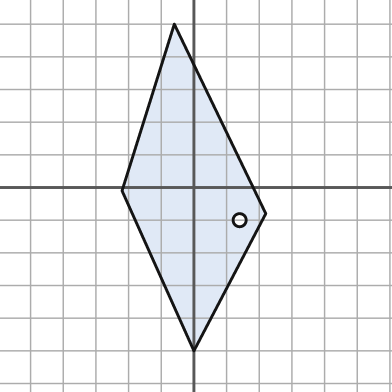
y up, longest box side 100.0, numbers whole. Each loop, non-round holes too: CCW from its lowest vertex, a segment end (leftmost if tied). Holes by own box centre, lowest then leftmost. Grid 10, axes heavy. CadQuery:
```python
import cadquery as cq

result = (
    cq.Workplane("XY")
    .moveTo(0.0, -50.0)
    .lineTo(22.0, -8.0)
    .lineTo(-6.0, 50.0)
    .lineTo(-22.0, -1.0)
    .close()
    .moveTo(14.0, -10.0)
    .circle(2.0)
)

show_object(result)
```